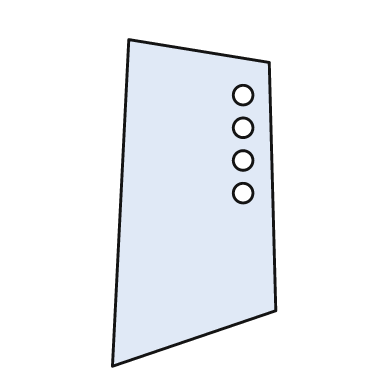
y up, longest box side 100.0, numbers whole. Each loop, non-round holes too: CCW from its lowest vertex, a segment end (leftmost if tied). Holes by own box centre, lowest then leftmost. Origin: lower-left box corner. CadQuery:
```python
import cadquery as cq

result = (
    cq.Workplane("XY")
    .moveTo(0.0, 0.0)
    .lineTo(50.0, 17.0)
    .lineTo(48.0, 93.0)
    .lineTo(5.0, 100.0)
    .close()
    .moveTo(40.0, 53.0)
    .circle(3.0)
    .moveTo(40.0, 63.0)
    .circle(3.0)
    .moveTo(40.0, 73.0)
    .circle(3.0)
    .moveTo(40.0, 83.0)
    .circle(3.0)
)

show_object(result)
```